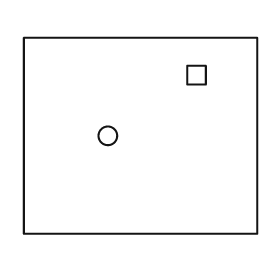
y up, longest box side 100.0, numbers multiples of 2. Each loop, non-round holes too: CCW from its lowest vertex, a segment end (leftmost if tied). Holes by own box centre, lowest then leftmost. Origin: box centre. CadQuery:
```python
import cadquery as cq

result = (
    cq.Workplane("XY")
    .moveTo(-50.0, -42.0)
    .lineTo(50.0, -42.0)
    .lineTo(50.0, 42.0)
    .lineTo(-50.0, 42.0)
    .close()
    .moveTo(-14.0, 0.0)
    .circle(4.0)
    .moveTo(20.0, 22.0)
    .lineTo(28.0, 22.0)
    .lineTo(28.0, 30.0)
    .lineTo(20.0, 30.0)
    .close()
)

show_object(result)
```